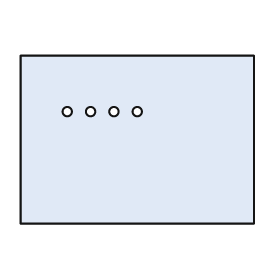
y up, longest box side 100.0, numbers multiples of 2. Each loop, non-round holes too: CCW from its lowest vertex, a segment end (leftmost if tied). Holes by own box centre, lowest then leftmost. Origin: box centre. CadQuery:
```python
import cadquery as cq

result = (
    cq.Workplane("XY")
    .moveTo(-50.0, -36.0)
    .lineTo(50.0, -36.0)
    .lineTo(50.0, 36.0)
    .lineTo(-50.0, 36.0)
    .close()
    .moveTo(-30.0, 12.0)
    .circle(2.0)
    .moveTo(-20.0, 12.0)
    .circle(2.0)
    .moveTo(-10.0, 12.0)
    .circle(2.0)
    .moveTo(0.0, 12.0)
    .circle(2.0)
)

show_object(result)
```